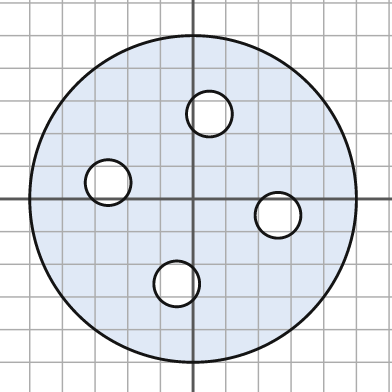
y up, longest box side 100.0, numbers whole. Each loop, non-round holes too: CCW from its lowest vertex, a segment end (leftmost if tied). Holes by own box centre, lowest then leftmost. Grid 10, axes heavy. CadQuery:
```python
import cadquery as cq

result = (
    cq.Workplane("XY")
    .moveTo(0.0, 0.0)
    .circle(50.0)
    .moveTo(-5.0, -26.0)
    .circle(7.0)
    .moveTo(26.0, -5.0)
    .circle(7.0)
    .moveTo(-26.0, 5.0)
    .circle(7.0)
    .moveTo(5.0, 26.0)
    .circle(7.0)
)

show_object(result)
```